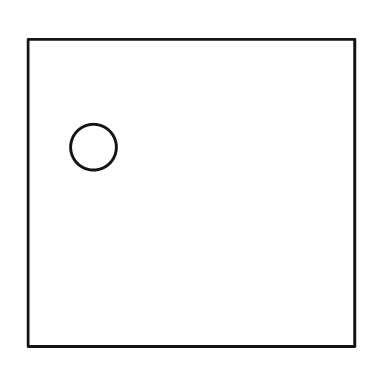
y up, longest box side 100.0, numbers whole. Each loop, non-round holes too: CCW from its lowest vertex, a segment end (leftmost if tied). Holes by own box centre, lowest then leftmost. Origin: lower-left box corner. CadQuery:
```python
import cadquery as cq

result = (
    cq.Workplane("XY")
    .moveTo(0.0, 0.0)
    .lineTo(100.0, 0.0)
    .lineTo(100.0, 94.0)
    .lineTo(0.0, 94.0)
    .close()
    .moveTo(20.0, 61.0)
    .circle(7.0)
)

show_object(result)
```